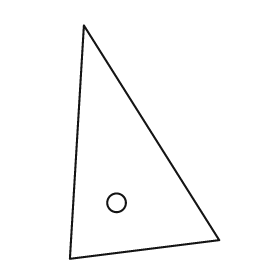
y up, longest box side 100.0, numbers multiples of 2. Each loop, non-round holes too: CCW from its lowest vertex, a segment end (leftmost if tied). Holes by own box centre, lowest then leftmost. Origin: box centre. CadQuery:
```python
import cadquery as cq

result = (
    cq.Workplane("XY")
    .moveTo(-32.0, -50.0)
    .lineTo(32.0, -42.0)
    .lineTo(-26.0, 50.0)
    .close()
    .moveTo(-12.0, -26.0)
    .circle(4.0)
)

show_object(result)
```